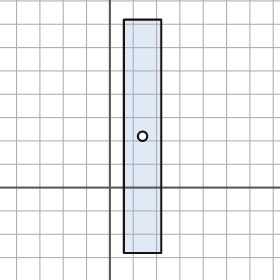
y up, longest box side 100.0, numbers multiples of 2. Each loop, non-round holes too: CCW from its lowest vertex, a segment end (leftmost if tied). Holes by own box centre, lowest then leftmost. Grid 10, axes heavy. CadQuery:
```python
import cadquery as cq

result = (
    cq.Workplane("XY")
    .moveTo(6.0, -28.0)
    .lineTo(22.0, -28.0)
    .lineTo(22.0, 72.0)
    .lineTo(6.0, 72.0)
    .close()
    .moveTo(14.0, 22.0)
    .circle(2.0)
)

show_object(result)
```